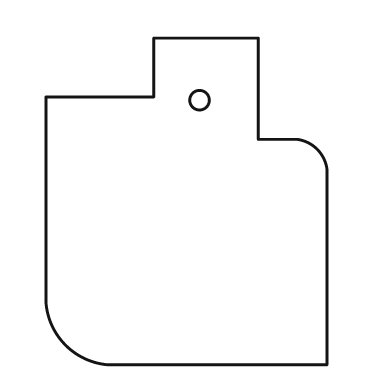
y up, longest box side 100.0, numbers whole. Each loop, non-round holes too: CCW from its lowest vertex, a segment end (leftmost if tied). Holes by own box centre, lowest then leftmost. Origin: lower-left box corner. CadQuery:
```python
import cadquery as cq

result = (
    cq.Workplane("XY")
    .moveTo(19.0, 0.0)
    .lineTo(86.0, 0.0)
    .lineTo(86.0, 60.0)
    .threePointArc((83.0, 66.0), (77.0, 69.0))
    .lineTo(65.0, 69.0)
    .lineTo(65.0, 100.0)
    .lineTo(33.0, 100.0)
    .lineTo(33.0, 82.0)
    .lineTo(0.0, 82.0)
    .lineTo(0.0, 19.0)
    .threePointArc((6.0, 6.0), (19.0, 0.0))
    .close()
    .moveTo(47.0, 81.0)
    .circle(3.0)
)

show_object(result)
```